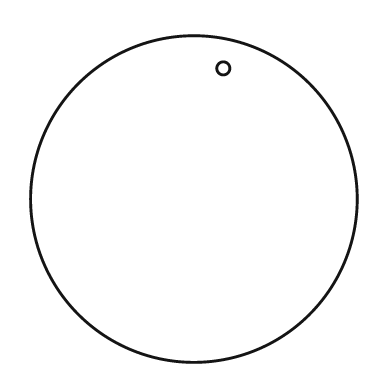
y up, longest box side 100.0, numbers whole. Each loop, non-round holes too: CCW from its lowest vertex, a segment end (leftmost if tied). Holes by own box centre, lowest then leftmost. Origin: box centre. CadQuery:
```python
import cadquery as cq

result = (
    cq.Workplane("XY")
    .moveTo(0.0, 0.0)
    .circle(50.0)
    .moveTo(9.0, 40.0)
    .circle(2.0)
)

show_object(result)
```